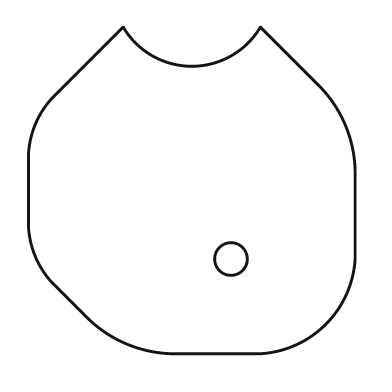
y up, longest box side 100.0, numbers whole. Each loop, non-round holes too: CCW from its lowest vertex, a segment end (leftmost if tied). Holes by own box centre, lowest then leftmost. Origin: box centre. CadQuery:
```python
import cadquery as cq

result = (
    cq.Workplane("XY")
    .moveTo(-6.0, -50.0)
    .lineTo(21.0, -50.0)
    .threePointArc((41.0, -41.0), (50.0, -21.0))
    .lineTo(50.0, 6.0)
    .threePointArc((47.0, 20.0), (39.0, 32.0))
    .lineTo(21.0, 50.0)
    .threePointArc((0.0, 38.0), (-21.0, 50.0))
    .lineTo(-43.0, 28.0)
    .threePointArc((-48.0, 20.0), (-50.0, 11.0))
    .lineTo(-50.0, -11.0)
    .threePointArc((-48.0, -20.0), (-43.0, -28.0))
    .lineTo(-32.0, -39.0)
    .threePointArc((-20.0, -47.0), (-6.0, -50.0))
    .close()
    .moveTo(12.0, -21.0)
    .circle(5.0)
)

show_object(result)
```